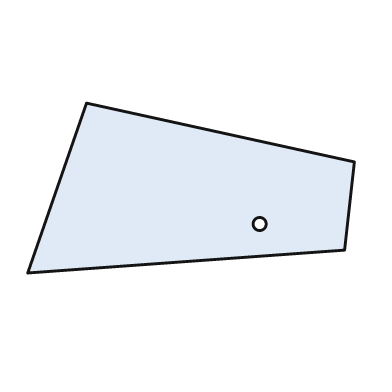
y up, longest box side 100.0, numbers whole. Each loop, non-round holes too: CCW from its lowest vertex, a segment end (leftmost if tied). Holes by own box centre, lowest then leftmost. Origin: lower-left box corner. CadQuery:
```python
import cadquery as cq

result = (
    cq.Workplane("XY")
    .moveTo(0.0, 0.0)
    .lineTo(97.0, 7.0)
    .lineTo(100.0, 34.0)
    .lineTo(18.0, 52.0)
    .close()
    .moveTo(71.0, 15.0)
    .circle(2.0)
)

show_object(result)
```